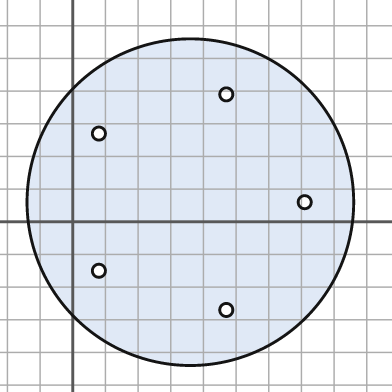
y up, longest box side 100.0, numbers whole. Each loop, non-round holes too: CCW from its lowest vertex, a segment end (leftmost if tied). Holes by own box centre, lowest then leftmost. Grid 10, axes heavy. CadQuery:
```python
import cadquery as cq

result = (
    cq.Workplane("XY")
    .moveTo(36.0, 6.0)
    .circle(50.0)
    .moveTo(47.0, -27.0)
    .circle(2.0)
    .moveTo(8.0, -15.0)
    .circle(2.0)
    .moveTo(71.0, 6.0)
    .circle(2.0)
    .moveTo(8.0, 27.0)
    .circle(2.0)
    .moveTo(47.0, 39.0)
    .circle(2.0)
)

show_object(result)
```